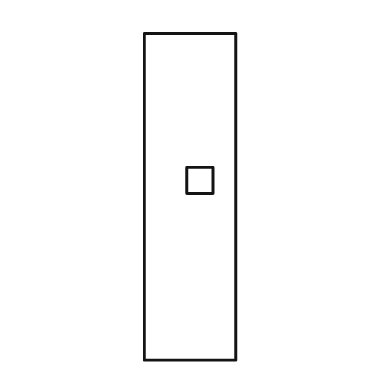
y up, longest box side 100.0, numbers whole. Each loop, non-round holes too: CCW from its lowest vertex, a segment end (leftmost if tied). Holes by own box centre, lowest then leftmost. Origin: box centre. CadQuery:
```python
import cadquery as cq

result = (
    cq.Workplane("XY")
    .moveTo(-14.0, -50.0)
    .lineTo(14.0, -50.0)
    .lineTo(14.0, 50.0)
    .lineTo(-14.0, 50.0)
    .close()
    .moveTo(-1.0, 1.0)
    .lineTo(7.0, 1.0)
    .lineTo(7.0, 9.0)
    .lineTo(-1.0, 9.0)
    .close()
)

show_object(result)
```